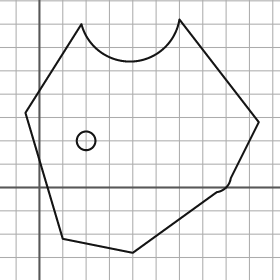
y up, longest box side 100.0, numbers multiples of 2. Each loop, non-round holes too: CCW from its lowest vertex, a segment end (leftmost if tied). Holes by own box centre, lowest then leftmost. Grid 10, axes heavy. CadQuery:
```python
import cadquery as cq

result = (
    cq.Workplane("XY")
    .moveTo(40.0, -28.0)
    .lineTo(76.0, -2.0)
    .threePointArc((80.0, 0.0), (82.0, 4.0))
    .lineTo(94.0, 28.0)
    .lineTo(60.0, 72.0)
    .threePointArc((40.0, 54.0), (18.0, 70.0))
    .lineTo(-6.0, 32.0)
    .lineTo(10.0, -22.0)
    .close()
    .moveTo(20.0, 20.0)
    .circle(4.0)
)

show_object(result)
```